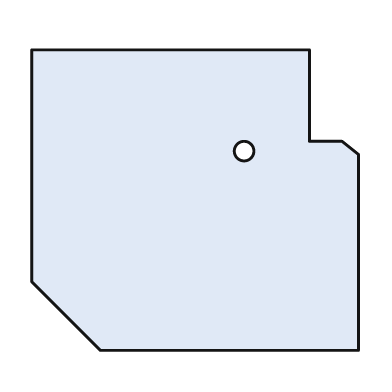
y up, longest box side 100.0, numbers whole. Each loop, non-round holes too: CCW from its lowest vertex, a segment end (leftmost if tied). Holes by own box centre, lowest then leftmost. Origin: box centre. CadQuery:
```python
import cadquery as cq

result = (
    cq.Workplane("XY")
    .moveTo(-29.0, -46.0)
    .lineTo(50.0, -46.0)
    .lineTo(50.0, 14.0)
    .lineTo(45.0, 18.0)
    .lineTo(35.0, 18.0)
    .lineTo(35.0, 46.0)
    .lineTo(-50.0, 46.0)
    .lineTo(-50.0, -25.0)
    .close()
    .moveTo(15.0, 15.0)
    .circle(3.0)
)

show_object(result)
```